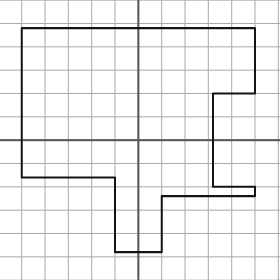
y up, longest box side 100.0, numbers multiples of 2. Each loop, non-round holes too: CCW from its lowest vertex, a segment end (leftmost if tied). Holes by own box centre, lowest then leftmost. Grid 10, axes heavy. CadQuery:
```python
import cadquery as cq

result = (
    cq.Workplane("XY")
    .moveTo(-10.0, -48.0)
    .lineTo(10.0, -48.0)
    .lineTo(10.0, -24.0)
    .lineTo(50.0, -24.0)
    .lineTo(50.0, -20.0)
    .lineTo(32.0, -20.0)
    .lineTo(32.0, 20.0)
    .lineTo(50.0, 20.0)
    .lineTo(50.0, 48.0)
    .lineTo(-50.0, 48.0)
    .lineTo(-50.0, -16.0)
    .lineTo(-10.0, -16.0)
    .close()
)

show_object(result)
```